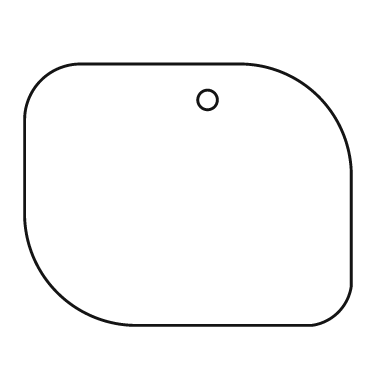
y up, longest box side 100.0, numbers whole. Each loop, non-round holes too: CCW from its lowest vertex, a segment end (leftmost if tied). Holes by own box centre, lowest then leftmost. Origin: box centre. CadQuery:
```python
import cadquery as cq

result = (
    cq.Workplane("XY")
    .moveTo(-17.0, -40.0)
    .lineTo(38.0, -40.0)
    .threePointArc((46.0, -36.0), (50.0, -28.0))
    .lineTo(50.0, 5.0)
    .threePointArc((40.0, 30.0), (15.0, 40.0))
    .lineTo(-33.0, 40.0)
    .threePointArc((-45.0, 35.0), (-50.0, 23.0))
    .lineTo(-50.0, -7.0)
    .threePointArc((-40.0, -30.0), (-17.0, -40.0))
    .close()
    .moveTo(6.0, 29.0)
    .circle(3.0)
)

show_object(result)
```